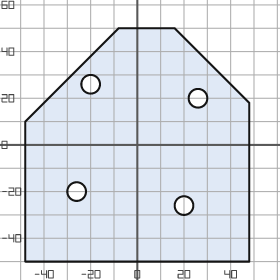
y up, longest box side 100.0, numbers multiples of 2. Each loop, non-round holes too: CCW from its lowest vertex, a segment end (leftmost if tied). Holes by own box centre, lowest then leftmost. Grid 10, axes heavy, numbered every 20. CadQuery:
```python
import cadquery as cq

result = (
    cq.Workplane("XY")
    .moveTo(-48.0, -50.0)
    .lineTo(48.0, -50.0)
    .lineTo(48.0, 18.0)
    .lineTo(16.0, 50.0)
    .lineTo(-8.0, 50.0)
    .lineTo(-48.0, 10.0)
    .close()
    .moveTo(20.0, -26.0)
    .circle(4.0)
    .moveTo(-26.0, -20.0)
    .circle(4.0)
    .moveTo(26.0, 20.0)
    .circle(4.0)
    .moveTo(-20.0, 26.0)
    .circle(4.0)
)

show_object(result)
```